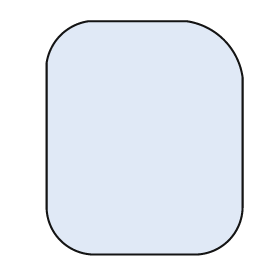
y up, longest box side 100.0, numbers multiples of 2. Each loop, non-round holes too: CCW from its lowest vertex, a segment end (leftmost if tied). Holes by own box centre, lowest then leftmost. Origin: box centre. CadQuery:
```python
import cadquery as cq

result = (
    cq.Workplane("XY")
    .moveTo(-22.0, -50.0)
    .lineTo(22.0, -50.0)
    .threePointArc((36.0, -44.0), (42.0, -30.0))
    .lineTo(42.0, 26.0)
    .threePointArc((34.0, 42.0), (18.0, 50.0))
    .lineTo(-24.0, 50.0)
    .threePointArc((-36.0, 44.0), (-42.0, 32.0))
    .lineTo(-42.0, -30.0)
    .threePointArc((-36.0, -44.0), (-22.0, -50.0))
    .close()
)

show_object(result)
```